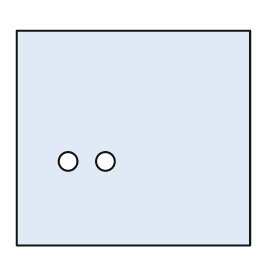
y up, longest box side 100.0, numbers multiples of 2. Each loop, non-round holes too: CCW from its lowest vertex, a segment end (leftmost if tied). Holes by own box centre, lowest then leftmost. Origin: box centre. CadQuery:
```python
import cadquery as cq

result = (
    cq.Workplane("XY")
    .moveTo(-50.0, -46.0)
    .lineTo(50.0, -46.0)
    .lineTo(50.0, 46.0)
    .lineTo(-50.0, 46.0)
    .close()
    .moveTo(-28.0, -10.0)
    .circle(4.0)
    .moveTo(-12.0, -10.0)
    .circle(4.0)
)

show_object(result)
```